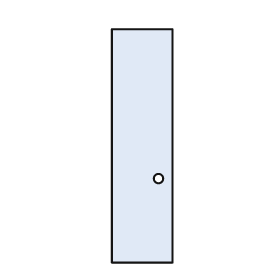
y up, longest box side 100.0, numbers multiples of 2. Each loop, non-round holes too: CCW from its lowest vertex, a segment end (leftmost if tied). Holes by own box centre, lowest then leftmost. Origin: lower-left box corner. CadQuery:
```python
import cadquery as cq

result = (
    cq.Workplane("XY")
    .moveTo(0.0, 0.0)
    .lineTo(26.0, 0.0)
    .lineTo(26.0, 100.0)
    .lineTo(0.0, 100.0)
    .close()
    .moveTo(20.0, 36.0)
    .circle(2.0)
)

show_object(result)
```